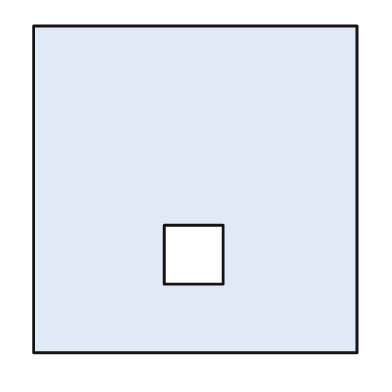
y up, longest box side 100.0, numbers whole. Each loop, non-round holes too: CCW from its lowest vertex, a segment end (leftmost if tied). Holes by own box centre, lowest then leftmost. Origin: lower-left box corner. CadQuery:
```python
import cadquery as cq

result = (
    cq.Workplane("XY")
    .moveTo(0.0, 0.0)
    .lineTo(99.0, 0.0)
    .lineTo(99.0, 100.0)
    .lineTo(0.0, 100.0)
    .close()
    .moveTo(40.0, 21.0)
    .lineTo(58.0, 21.0)
    .lineTo(58.0, 39.0)
    .lineTo(40.0, 39.0)
    .close()
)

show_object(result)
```